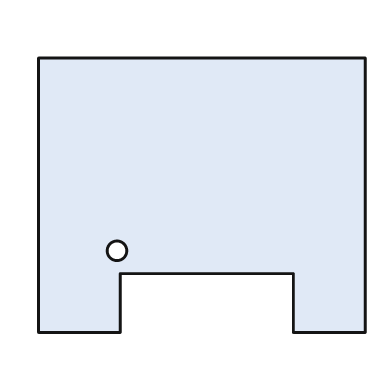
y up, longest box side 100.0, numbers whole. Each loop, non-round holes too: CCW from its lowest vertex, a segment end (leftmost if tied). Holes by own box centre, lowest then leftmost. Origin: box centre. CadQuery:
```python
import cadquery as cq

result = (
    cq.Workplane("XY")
    .moveTo(-50.0, -42.0)
    .lineTo(-25.0, -42.0)
    .lineTo(-25.0, -24.0)
    .lineTo(28.0, -24.0)
    .lineTo(28.0, -42.0)
    .lineTo(50.0, -42.0)
    .lineTo(50.0, 42.0)
    .lineTo(-50.0, 42.0)
    .close()
    .moveTo(-26.0, -17.0)
    .circle(3.0)
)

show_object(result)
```